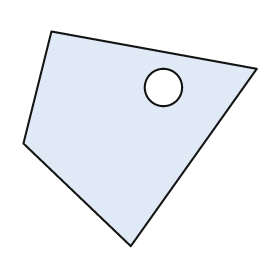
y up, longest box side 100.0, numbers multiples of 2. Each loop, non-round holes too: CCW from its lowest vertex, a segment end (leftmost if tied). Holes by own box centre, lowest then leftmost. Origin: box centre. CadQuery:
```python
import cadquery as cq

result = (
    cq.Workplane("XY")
    .moveTo(-4.0, -46.0)
    .lineTo(50.0, 30.0)
    .lineTo(-38.0, 46.0)
    .lineTo(-50.0, -2.0)
    .close()
    .moveTo(10.0, 22.0)
    .circle(8.0)
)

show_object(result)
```